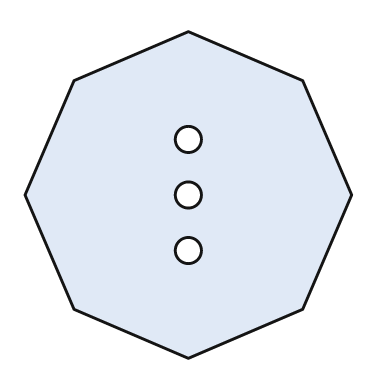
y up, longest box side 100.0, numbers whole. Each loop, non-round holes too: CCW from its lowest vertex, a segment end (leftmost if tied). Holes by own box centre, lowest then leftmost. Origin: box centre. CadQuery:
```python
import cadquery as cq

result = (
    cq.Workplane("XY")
    .moveTo(0.0, -50.0)
    .lineTo(35.0, -35.0)
    .lineTo(50.0, 0.0)
    .lineTo(35.0, 35.0)
    .lineTo(0.0, 50.0)
    .lineTo(-35.0, 35.0)
    .lineTo(-50.0, 0.0)
    .lineTo(-35.0, -35.0)
    .close()
    .moveTo(0.0, -17.0)
    .circle(4.0)
    .moveTo(0.0, 0.0)
    .circle(4.0)
    .moveTo(0.0, 17.0)
    .circle(4.0)
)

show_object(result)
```